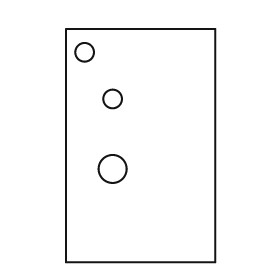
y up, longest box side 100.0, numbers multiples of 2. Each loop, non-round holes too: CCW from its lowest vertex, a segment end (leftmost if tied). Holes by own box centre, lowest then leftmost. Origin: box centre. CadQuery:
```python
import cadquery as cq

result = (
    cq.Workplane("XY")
    .moveTo(-32.0, -50.0)
    .lineTo(32.0, -50.0)
    .lineTo(32.0, 50.0)
    .lineTo(-32.0, 50.0)
    .close()
    .moveTo(-12.0, -10.0)
    .circle(6.0)
    .moveTo(-12.0, 20.0)
    .circle(4.0)
    .moveTo(-24.0, 40.0)
    .circle(4.0)
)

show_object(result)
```